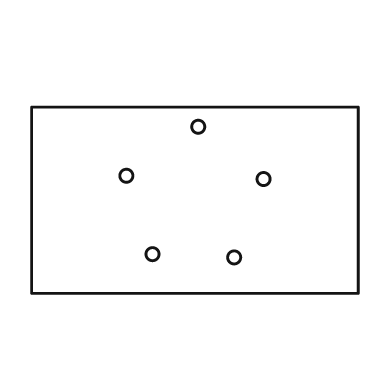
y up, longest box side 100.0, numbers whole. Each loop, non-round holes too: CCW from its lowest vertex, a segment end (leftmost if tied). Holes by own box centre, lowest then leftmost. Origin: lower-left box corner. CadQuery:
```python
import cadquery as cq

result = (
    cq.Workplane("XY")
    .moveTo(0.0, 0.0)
    .lineTo(100.0, 0.0)
    .lineTo(100.0, 57.0)
    .lineTo(0.0, 57.0)
    .close()
    .moveTo(62.0, 11.0)
    .circle(2.0)
    .moveTo(37.0, 12.0)
    .circle(2.0)
    .moveTo(71.0, 35.0)
    .circle(2.0)
    .moveTo(29.0, 36.0)
    .circle(2.0)
    .moveTo(51.0, 51.0)
    .circle(2.0)
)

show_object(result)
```